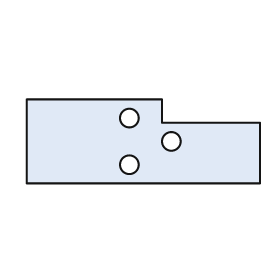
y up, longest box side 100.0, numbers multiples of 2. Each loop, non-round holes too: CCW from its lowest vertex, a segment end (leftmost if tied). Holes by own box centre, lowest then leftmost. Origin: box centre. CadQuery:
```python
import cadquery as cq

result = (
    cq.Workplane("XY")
    .moveTo(-50.0, -18.0)
    .lineTo(50.0, -18.0)
    .lineTo(50.0, 8.0)
    .lineTo(8.0, 8.0)
    .lineTo(8.0, 18.0)
    .lineTo(-50.0, 18.0)
    .close()
    .moveTo(-6.0, -10.0)
    .circle(4.0)
    .moveTo(12.0, 0.0)
    .circle(4.0)
    .moveTo(-6.0, 10.0)
    .circle(4.0)
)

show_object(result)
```